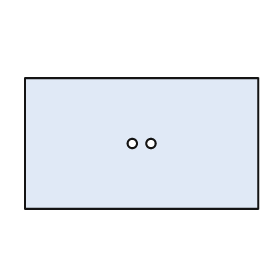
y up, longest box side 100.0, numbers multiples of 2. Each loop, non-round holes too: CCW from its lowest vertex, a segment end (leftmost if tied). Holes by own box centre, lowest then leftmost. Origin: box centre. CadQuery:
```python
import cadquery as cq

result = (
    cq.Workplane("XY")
    .moveTo(-50.0, -28.0)
    .lineTo(50.0, -28.0)
    .lineTo(50.0, 28.0)
    .lineTo(-50.0, 28.0)
    .close()
    .moveTo(-4.0, 0.0)
    .circle(2.0)
    .moveTo(4.0, 0.0)
    .circle(2.0)
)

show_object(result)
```